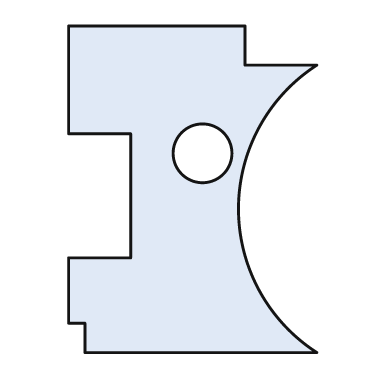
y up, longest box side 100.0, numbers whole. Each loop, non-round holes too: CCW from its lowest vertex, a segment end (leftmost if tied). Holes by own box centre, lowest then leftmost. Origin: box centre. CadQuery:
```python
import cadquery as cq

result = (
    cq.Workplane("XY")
    .moveTo(-33.0, -50.0)
    .lineTo(38.0, -50.0)
    .threePointArc((14.0, -6.0), (38.0, 38.0))
    .lineTo(16.0, 38.0)
    .lineTo(16.0, 50.0)
    .lineTo(-38.0, 50.0)
    .lineTo(-38.0, 17.0)
    .lineTo(-19.0, 17.0)
    .lineTo(-19.0, -21.0)
    .lineTo(-38.0, -21.0)
    .lineTo(-38.0, -41.0)
    .lineTo(-33.0, -41.0)
    .close()
    .moveTo(3.0, 11.0)
    .circle(9.0)
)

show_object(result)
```